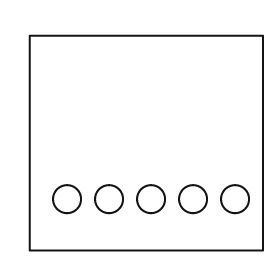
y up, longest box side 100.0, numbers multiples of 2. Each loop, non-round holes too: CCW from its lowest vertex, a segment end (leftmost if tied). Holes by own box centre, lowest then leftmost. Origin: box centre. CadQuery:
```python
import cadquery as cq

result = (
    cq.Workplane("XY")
    .moveTo(-50.0, -46.0)
    .lineTo(50.0, -46.0)
    .lineTo(50.0, 46.0)
    .lineTo(-50.0, 46.0)
    .close()
    .moveTo(-34.0, -24.0)
    .circle(6.0)
    .moveTo(-16.0, -24.0)
    .circle(6.0)
    .moveTo(2.0, -24.0)
    .circle(6.0)
    .moveTo(20.0, -24.0)
    .circle(6.0)
    .moveTo(38.0, -24.0)
    .circle(6.0)
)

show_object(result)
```